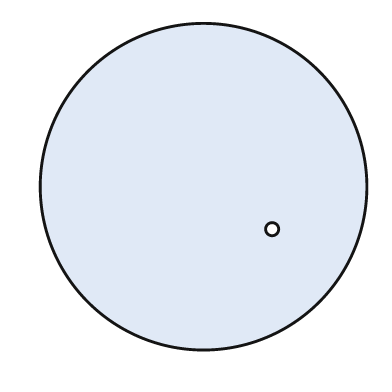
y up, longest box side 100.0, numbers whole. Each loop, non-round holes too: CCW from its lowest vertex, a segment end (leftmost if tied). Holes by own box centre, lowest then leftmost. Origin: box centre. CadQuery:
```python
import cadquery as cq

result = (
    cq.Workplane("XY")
    .moveTo(0.0, 0.0)
    .circle(50.0)
    .moveTo(21.0, -13.0)
    .circle(2.0)
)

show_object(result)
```